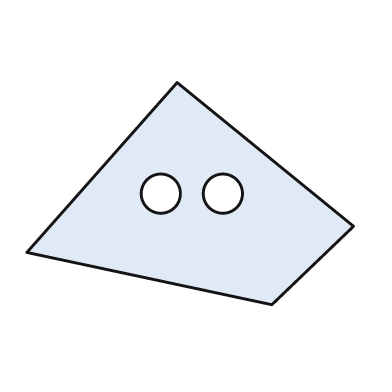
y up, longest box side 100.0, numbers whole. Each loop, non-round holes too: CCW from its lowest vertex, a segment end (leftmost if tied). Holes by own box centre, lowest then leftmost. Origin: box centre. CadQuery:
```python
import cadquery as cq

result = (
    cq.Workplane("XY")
    .moveTo(25.0, -34.0)
    .lineTo(50.0, -10.0)
    .lineTo(-4.0, 34.0)
    .lineTo(-50.0, -18.0)
    .close()
    .moveTo(-9.0, 0.0)
    .circle(6.0)
    .moveTo(10.0, 0.0)
    .circle(6.0)
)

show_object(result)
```